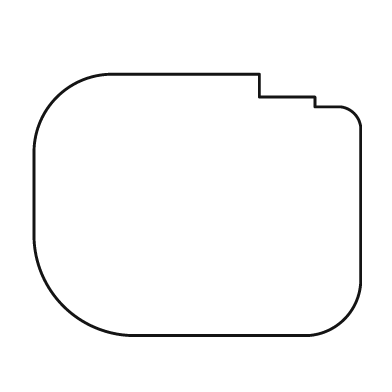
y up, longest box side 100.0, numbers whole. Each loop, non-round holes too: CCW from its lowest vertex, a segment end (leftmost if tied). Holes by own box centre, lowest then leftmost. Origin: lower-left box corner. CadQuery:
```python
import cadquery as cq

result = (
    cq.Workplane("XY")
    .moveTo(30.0, 0.0)
    .lineTo(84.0, 0.0)
    .threePointArc((95.0, 5.0), (100.0, 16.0))
    .lineTo(100.0, 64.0)
    .threePointArc((98.0, 68.0), (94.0, 70.0))
    .lineTo(86.0, 70.0)
    .lineTo(86.0, 73.0)
    .lineTo(69.0, 73.0)
    .lineTo(69.0, 80.0)
    .lineTo(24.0, 80.0)
    .threePointArc((7.0, 73.0), (0.0, 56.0))
    .lineTo(0.0, 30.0)
    .threePointArc((9.0, 9.0), (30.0, 0.0))
    .close()
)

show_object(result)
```